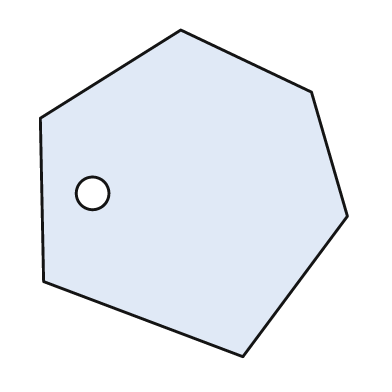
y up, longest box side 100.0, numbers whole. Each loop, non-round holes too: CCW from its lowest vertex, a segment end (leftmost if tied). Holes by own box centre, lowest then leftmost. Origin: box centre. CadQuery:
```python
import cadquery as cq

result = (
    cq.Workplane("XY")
    .moveTo(15.0, -50.0)
    .lineTo(47.0, -7.0)
    .lineTo(36.0, 31.0)
    .lineTo(-4.0, 50.0)
    .lineTo(-47.0, 23.0)
    .lineTo(-46.0, -27.0)
    .close()
    .moveTo(-31.0, 0.0)
    .circle(5.0)
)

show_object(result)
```